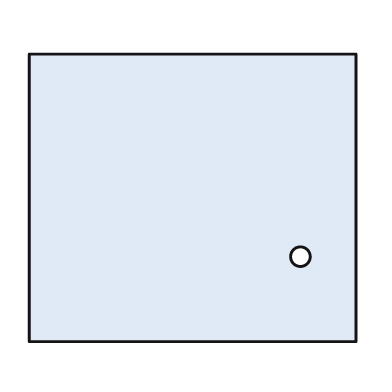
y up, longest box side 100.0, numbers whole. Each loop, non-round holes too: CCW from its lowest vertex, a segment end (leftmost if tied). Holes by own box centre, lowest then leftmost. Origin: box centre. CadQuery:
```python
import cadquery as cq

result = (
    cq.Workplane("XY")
    .moveTo(-50.0, -44.0)
    .lineTo(50.0, -44.0)
    .lineTo(50.0, 44.0)
    .lineTo(-50.0, 44.0)
    .close()
    .moveTo(33.0, -18.0)
    .circle(3.0)
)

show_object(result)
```